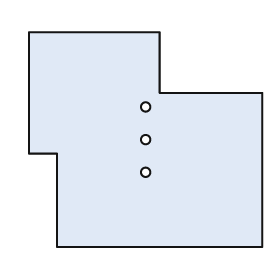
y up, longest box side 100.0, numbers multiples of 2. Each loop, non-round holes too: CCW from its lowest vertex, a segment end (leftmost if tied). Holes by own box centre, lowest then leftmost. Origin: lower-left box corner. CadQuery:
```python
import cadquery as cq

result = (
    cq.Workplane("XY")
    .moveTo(12.0, 0.0)
    .lineTo(100.0, 0.0)
    .lineTo(100.0, 66.0)
    .lineTo(56.0, 66.0)
    .lineTo(56.0, 92.0)
    .lineTo(0.0, 92.0)
    .lineTo(0.0, 40.0)
    .lineTo(12.0, 40.0)
    .close()
    .moveTo(50.0, 32.0)
    .circle(2.0)
    .moveTo(50.0, 46.0)
    .circle(2.0)
    .moveTo(50.0, 60.0)
    .circle(2.0)
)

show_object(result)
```